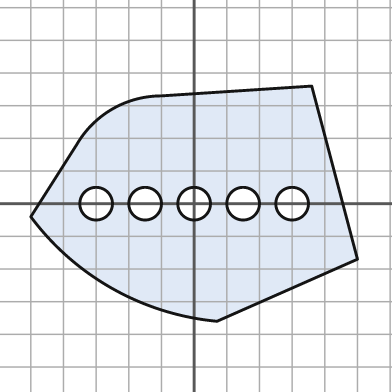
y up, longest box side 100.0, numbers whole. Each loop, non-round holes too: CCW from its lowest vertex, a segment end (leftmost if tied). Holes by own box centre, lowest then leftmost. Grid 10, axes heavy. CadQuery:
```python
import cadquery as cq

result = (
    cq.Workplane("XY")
    .moveTo(7.0, -36.0)
    .lineTo(50.0, -17.0)
    .lineTo(36.0, 36.0)
    .lineTo(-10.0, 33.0)
    .threePointArc((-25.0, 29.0), (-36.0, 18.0))
    .lineTo(-50.0, -4.0)
    .threePointArc((-25.0, -26.0), (7.0, -36.0))
    .close()
    .moveTo(-30.0, 0.0)
    .circle(5.0)
    .moveTo(-15.0, 0.0)
    .circle(5.0)
    .moveTo(0.0, 0.0)
    .circle(5.0)
    .moveTo(15.0, 0.0)
    .circle(5.0)
    .moveTo(30.0, 0.0)
    .circle(5.0)
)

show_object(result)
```